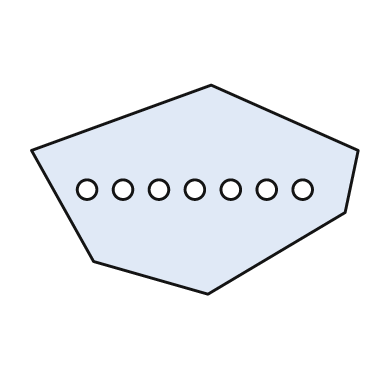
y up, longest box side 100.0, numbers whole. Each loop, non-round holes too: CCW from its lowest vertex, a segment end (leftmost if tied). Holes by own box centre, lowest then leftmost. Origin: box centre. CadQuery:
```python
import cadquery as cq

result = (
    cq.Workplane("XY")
    .moveTo(4.0, -32.0)
    .lineTo(46.0, -7.0)
    .lineTo(50.0, 12.0)
    .lineTo(5.0, 32.0)
    .lineTo(-50.0, 12.0)
    .lineTo(-31.0, -22.0)
    .close()
    .moveTo(-33.0, 0.0)
    .circle(3.0)
    .moveTo(-22.0, 0.0)
    .circle(3.0)
    .moveTo(-11.0, 0.0)
    .circle(3.0)
    .moveTo(0.0, 0.0)
    .circle(3.0)
    .moveTo(11.0, 0.0)
    .circle(3.0)
    .moveTo(22.0, 0.0)
    .circle(3.0)
    .moveTo(33.0, 0.0)
    .circle(3.0)
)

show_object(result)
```